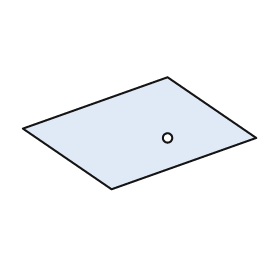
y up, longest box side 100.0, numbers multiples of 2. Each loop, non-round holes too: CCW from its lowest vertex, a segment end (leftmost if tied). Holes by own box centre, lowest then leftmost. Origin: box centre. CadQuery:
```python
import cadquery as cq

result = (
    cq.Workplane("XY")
    .moveTo(-12.0, -24.0)
    .lineTo(50.0, -2.0)
    .lineTo(12.0, 24.0)
    .lineTo(-50.0, 2.0)
    .close()
    .moveTo(12.0, -2.0)
    .circle(2.0)
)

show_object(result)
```